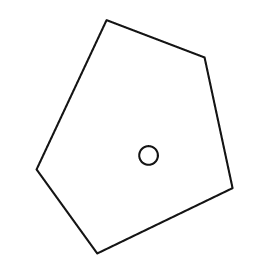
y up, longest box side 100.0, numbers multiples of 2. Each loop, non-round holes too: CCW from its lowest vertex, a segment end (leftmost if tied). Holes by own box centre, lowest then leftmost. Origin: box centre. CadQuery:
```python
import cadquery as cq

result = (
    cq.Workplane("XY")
    .moveTo(-16.0, -50.0)
    .lineTo(42.0, -22.0)
    .lineTo(30.0, 34.0)
    .lineTo(-12.0, 50.0)
    .lineTo(-42.0, -14.0)
    .close()
    .moveTo(6.0, -8.0)
    .circle(4.0)
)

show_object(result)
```